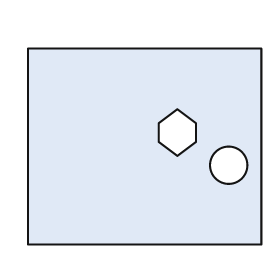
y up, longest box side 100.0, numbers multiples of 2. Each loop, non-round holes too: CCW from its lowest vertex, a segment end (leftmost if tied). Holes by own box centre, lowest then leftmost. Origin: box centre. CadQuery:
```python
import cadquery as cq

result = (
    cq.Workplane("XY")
    .moveTo(-50.0, -42.0)
    .lineTo(50.0, -42.0)
    .lineTo(50.0, 42.0)
    .lineTo(-50.0, 42.0)
    .close()
    .moveTo(36.0, -8.0)
    .circle(8.0)
    .moveTo(14.0, -4.0)
    .lineTo(22.0, 2.0)
    .lineTo(22.0, 10.0)
    .lineTo(14.0, 16.0)
    .lineTo(6.0, 10.0)
    .lineTo(6.0, 2.0)
    .close()
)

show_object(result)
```